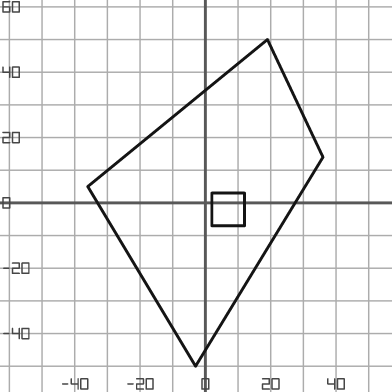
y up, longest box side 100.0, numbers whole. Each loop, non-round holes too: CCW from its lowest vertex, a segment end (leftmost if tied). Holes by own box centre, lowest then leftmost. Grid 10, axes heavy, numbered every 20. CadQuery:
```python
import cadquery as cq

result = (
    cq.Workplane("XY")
    .moveTo(-3.0, -50.0)
    .lineTo(36.0, 14.0)
    .lineTo(19.0, 50.0)
    .lineTo(-36.0, 5.0)
    .close()
    .moveTo(2.0, -7.0)
    .lineTo(12.0, -7.0)
    .lineTo(12.0, 3.0)
    .lineTo(2.0, 3.0)
    .close()
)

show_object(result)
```